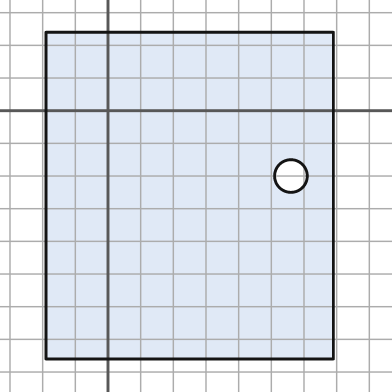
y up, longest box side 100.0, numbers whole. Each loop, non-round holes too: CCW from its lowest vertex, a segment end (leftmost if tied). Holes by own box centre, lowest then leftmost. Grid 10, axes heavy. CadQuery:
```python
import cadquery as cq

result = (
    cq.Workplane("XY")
    .moveTo(-19.0, -76.0)
    .lineTo(69.0, -76.0)
    .lineTo(69.0, 24.0)
    .lineTo(-19.0, 24.0)
    .close()
    .moveTo(56.0, -20.0)
    .circle(5.0)
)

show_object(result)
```